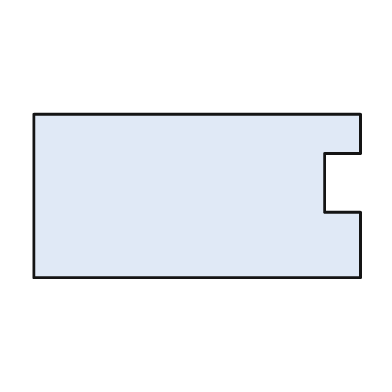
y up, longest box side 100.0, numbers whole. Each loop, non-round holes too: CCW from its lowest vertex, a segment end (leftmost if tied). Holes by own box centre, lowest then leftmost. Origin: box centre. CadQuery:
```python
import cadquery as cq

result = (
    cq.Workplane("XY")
    .moveTo(-50.0, -25.0)
    .lineTo(50.0, -25.0)
    .lineTo(50.0, -5.0)
    .lineTo(39.0, -5.0)
    .lineTo(39.0, 13.0)
    .lineTo(50.0, 13.0)
    .lineTo(50.0, 25.0)
    .lineTo(-50.0, 25.0)
    .close()
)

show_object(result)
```